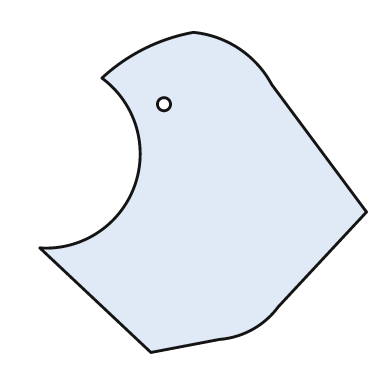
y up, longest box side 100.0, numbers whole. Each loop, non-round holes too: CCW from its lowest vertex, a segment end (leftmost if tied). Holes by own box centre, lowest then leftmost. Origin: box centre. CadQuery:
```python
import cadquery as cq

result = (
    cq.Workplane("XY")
    .moveTo(-16.0, -49.0)
    .lineTo(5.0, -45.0)
    .threePointArc((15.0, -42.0), (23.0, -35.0))
    .lineTo(50.0, -6.0)
    .lineTo(21.0, 33.0)
    .threePointArc((11.0, 44.0), (-3.0, 49.0))
    .threePointArc((-18.0, 44.0), (-31.0, 35.0))
    .threePointArc((-21.0, 2.0), (-50.0, -17.0))
    .close()
    .moveTo(-12.0, 27.0)
    .circle(2.0)
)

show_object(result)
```